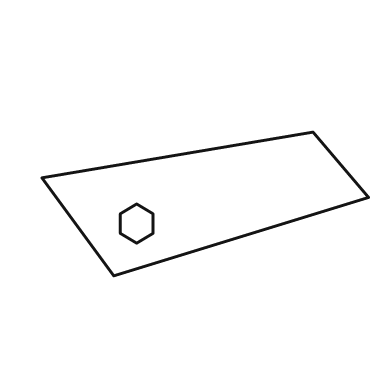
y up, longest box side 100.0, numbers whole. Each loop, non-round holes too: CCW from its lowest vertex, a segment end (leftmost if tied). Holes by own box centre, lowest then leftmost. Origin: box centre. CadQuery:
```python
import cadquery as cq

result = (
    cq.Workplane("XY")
    .moveTo(-28.0, -22.0)
    .lineTo(50.0, 2.0)
    .lineTo(33.0, 22.0)
    .lineTo(-50.0, 8.0)
    .close()
    .moveTo(-21.0, -12.0)
    .lineTo(-16.0, -9.0)
    .lineTo(-16.0, -3.0)
    .lineTo(-21.0, 0.0)
    .lineTo(-26.0, -3.0)
    .lineTo(-26.0, -9.0)
    .close()
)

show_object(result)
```